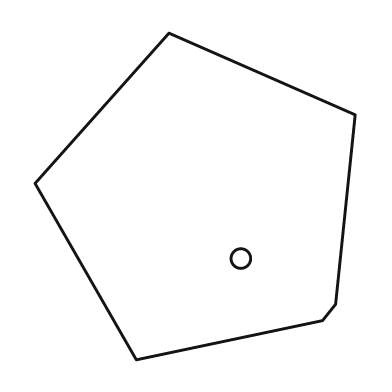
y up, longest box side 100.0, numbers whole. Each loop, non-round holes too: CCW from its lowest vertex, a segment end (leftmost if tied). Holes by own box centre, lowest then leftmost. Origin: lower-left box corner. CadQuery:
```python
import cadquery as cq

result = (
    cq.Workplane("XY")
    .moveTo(31.0, 0.0)
    .lineTo(88.0, 12.0)
    .lineTo(92.0, 17.0)
    .lineTo(98.0, 75.0)
    .lineTo(41.0, 100.0)
    .lineTo(0.0, 54.0)
    .close()
    .moveTo(63.0, 31.0)
    .circle(3.0)
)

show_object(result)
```